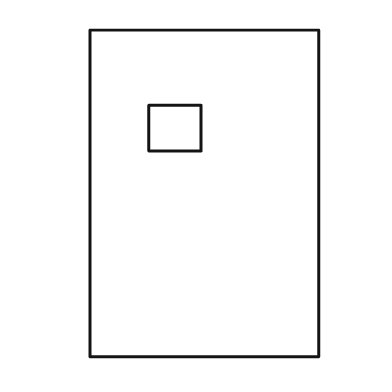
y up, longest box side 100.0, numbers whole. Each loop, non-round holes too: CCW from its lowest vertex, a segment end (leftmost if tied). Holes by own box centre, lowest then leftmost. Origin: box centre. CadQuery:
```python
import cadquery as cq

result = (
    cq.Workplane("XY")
    .moveTo(-35.0, -50.0)
    .lineTo(35.0, -50.0)
    .lineTo(35.0, 50.0)
    .lineTo(-35.0, 50.0)
    .close()
    .moveTo(-17.0, 13.0)
    .lineTo(-1.0, 13.0)
    .lineTo(-1.0, 27.0)
    .lineTo(-17.0, 27.0)
    .close()
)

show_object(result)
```